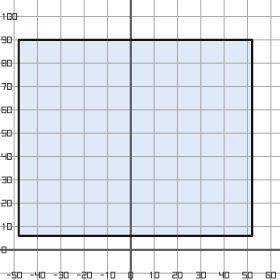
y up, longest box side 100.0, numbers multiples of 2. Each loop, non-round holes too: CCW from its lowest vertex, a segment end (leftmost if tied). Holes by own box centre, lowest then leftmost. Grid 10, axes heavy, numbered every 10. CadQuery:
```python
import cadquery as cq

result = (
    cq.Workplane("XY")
    .moveTo(-48.0, 6.0)
    .lineTo(52.0, 6.0)
    .lineTo(52.0, 90.0)
    .lineTo(-48.0, 90.0)
    .close()
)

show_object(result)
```